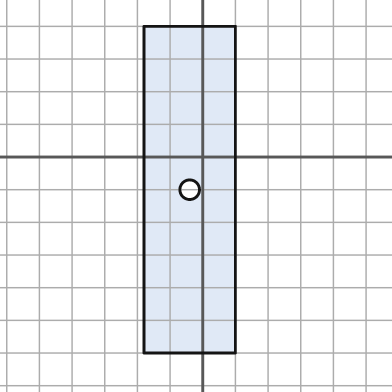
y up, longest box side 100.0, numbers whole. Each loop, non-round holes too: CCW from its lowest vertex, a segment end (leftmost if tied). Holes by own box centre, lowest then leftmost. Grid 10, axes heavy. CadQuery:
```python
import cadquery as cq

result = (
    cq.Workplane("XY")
    .moveTo(-18.0, -60.0)
    .lineTo(10.0, -60.0)
    .lineTo(10.0, 40.0)
    .lineTo(-18.0, 40.0)
    .close()
    .moveTo(-4.0, -10.0)
    .circle(3.0)
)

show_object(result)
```